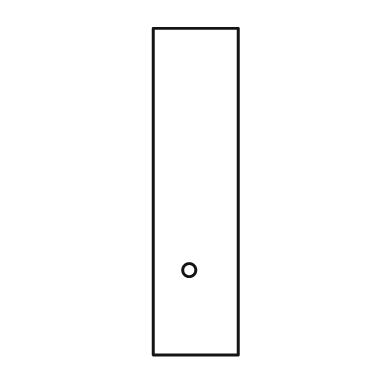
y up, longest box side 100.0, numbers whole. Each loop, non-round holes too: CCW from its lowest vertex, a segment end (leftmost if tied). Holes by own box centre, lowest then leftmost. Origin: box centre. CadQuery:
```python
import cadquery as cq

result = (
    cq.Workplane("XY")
    .moveTo(-13.0, -50.0)
    .lineTo(13.0, -50.0)
    .lineTo(13.0, 50.0)
    .lineTo(-13.0, 50.0)
    .close()
    .moveTo(-2.0, -24.0)
    .circle(2.0)
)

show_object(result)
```